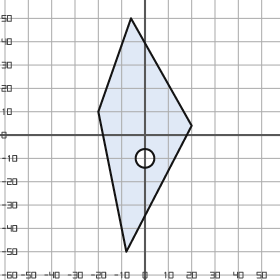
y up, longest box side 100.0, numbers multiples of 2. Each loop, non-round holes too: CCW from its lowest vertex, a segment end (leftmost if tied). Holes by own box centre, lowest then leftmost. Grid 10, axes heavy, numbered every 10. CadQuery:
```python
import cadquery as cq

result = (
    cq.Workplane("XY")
    .moveTo(-8.0, -50.0)
    .lineTo(20.0, 4.0)
    .lineTo(-6.0, 50.0)
    .lineTo(-20.0, 10.0)
    .close()
    .moveTo(0.0, -10.0)
    .circle(4.0)
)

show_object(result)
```